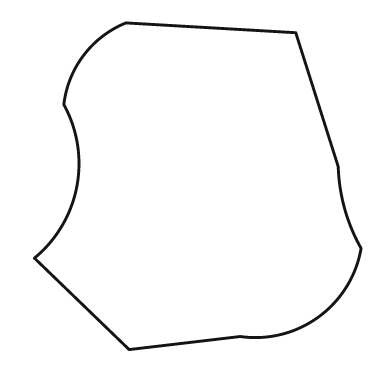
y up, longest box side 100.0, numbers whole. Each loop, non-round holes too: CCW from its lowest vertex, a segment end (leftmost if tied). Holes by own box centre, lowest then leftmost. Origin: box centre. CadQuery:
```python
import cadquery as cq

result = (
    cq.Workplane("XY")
    .moveTo(-21.0, -50.0)
    .lineTo(13.0, -46.0)
    .threePointArc((37.0, -40.0), (50.0, -19.0))
    .threePointArc((45.0, -7.0), (43.0, 6.0))
    .lineTo(30.0, 47.0)
    .lineTo(-22.0, 50.0)
    .threePointArc((-35.0, 40.0), (-41.0, 25.0))
    .threePointArc((-37.0, 0.0), (-50.0, -22.0))
    .close()
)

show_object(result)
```